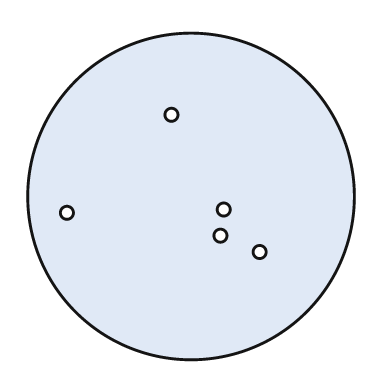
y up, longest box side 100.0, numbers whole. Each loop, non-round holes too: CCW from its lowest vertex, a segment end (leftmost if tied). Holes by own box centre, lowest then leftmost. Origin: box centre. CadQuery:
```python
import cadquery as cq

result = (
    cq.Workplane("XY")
    .moveTo(0.0, 0.0)
    .circle(50.0)
    .moveTo(21.0, -17.0)
    .circle(2.0)
    .moveTo(9.0, -12.0)
    .circle(2.0)
    .moveTo(-38.0, -5.0)
    .circle(2.0)
    .moveTo(10.0, -4.0)
    .circle(2.0)
    .moveTo(-6.0, 25.0)
    .circle(2.0)
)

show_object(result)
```